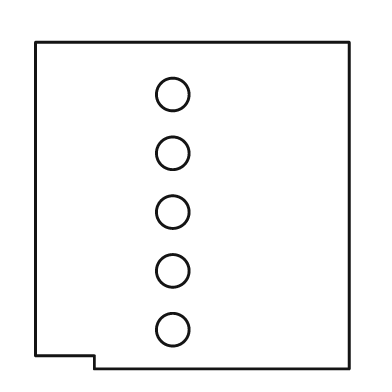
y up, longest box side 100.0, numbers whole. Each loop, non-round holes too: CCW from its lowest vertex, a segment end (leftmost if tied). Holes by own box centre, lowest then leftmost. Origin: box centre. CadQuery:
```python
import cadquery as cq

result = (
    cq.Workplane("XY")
    .moveTo(-30.0, -50.0)
    .lineTo(48.0, -50.0)
    .lineTo(48.0, 50.0)
    .lineTo(-48.0, 50.0)
    .lineTo(-48.0, -46.0)
    .lineTo(-30.0, -46.0)
    .close()
    .moveTo(-6.0, -38.0)
    .circle(5.0)
    .moveTo(-6.0, -20.0)
    .circle(5.0)
    .moveTo(-6.0, -2.0)
    .circle(5.0)
    .moveTo(-6.0, 16.0)
    .circle(5.0)
    .moveTo(-6.0, 34.0)
    .circle(5.0)
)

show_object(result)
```